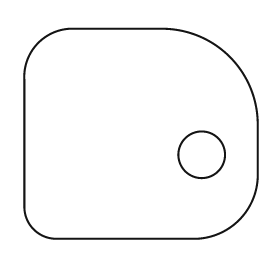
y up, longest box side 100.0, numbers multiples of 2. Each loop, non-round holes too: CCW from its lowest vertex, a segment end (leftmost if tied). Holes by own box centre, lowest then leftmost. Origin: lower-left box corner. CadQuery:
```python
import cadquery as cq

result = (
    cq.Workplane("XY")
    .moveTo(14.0, 0.0)
    .lineTo(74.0, 0.0)
    .threePointArc((92.0, 8.0), (100.0, 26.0))
    .lineTo(100.0, 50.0)
    .threePointArc((88.0, 78.0), (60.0, 90.0))
    .lineTo(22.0, 90.0)
    .threePointArc((6.0, 84.0), (0.0, 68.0))
    .lineTo(0.0, 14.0)
    .threePointArc((4.0, 4.0), (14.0, 0.0))
    .close()
    .moveTo(76.0, 36.0)
    .circle(10.0)
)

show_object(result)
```